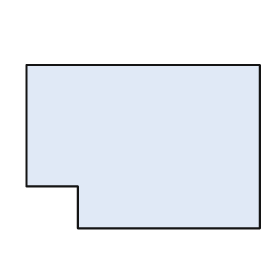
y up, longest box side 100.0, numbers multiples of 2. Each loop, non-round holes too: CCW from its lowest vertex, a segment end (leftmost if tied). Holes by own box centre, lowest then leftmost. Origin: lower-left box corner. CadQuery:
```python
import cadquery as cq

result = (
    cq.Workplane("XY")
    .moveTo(22.0, 0.0)
    .lineTo(100.0, 0.0)
    .lineTo(100.0, 70.0)
    .lineTo(0.0, 70.0)
    .lineTo(0.0, 18.0)
    .lineTo(22.0, 18.0)
    .close()
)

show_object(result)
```